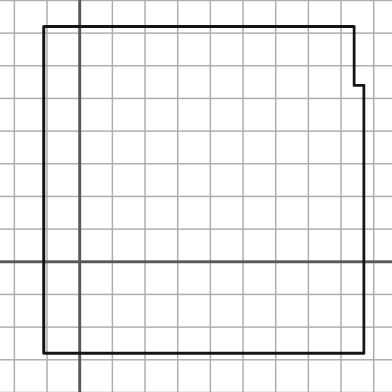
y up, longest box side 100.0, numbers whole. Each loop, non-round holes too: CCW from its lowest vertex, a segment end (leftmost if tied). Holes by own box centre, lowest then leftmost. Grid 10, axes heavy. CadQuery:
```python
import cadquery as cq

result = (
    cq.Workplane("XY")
    .moveTo(-11.0, -28.0)
    .lineTo(87.0, -28.0)
    .lineTo(87.0, 54.0)
    .lineTo(84.0, 54.0)
    .lineTo(84.0, 72.0)
    .lineTo(-11.0, 72.0)
    .close()
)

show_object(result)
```